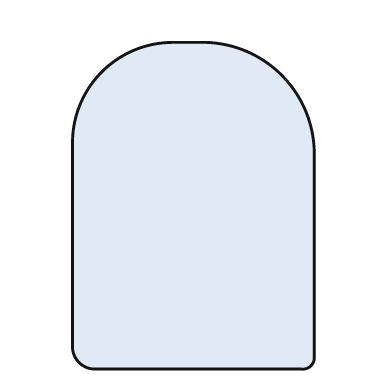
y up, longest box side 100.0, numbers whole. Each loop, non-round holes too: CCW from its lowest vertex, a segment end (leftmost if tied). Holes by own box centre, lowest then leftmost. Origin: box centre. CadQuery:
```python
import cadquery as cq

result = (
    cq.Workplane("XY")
    .moveTo(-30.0, -50.0)
    .lineTo(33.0, -50.0)
    .threePointArc((36.0, -49.0), (37.0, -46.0))
    .lineTo(37.0, 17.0)
    .threePointArc((27.0, 40.0), (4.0, 50.0))
    .lineTo(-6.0, 50.0)
    .threePointArc((-28.0, 41.0), (-37.0, 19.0))
    .lineTo(-37.0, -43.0)
    .threePointArc((-35.0, -48.0), (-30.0, -50.0))
    .close()
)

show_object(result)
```